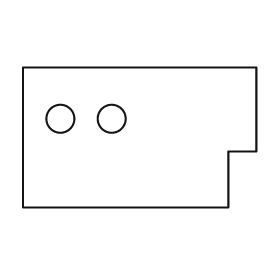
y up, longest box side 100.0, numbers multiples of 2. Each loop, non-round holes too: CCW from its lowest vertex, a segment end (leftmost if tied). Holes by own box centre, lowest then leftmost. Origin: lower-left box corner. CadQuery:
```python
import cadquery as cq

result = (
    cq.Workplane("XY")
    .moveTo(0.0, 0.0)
    .lineTo(88.0, 0.0)
    .lineTo(88.0, 24.0)
    .lineTo(100.0, 24.0)
    .lineTo(100.0, 60.0)
    .lineTo(0.0, 60.0)
    .close()
    .moveTo(16.0, 38.0)
    .circle(6.0)
    .moveTo(38.0, 38.0)
    .circle(6.0)
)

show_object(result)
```